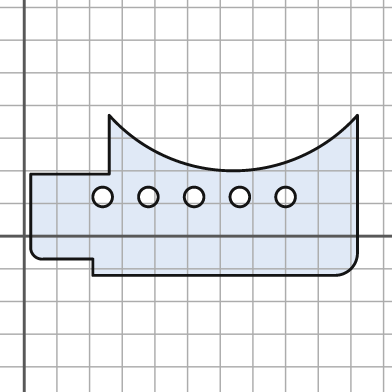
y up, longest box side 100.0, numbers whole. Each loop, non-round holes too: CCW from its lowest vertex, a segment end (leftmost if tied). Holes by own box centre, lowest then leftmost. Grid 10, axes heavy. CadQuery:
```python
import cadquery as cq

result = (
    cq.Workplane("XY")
    .moveTo(21.0, -12.0)
    .lineTo(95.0, -12.0)
    .threePointArc((100.0, -10.0), (102.0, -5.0))
    .lineTo(102.0, 37.0)
    .threePointArc((64.0, 20.0), (26.0, 37.0))
    .lineTo(26.0, 19.0)
    .lineTo(2.0, 19.0)
    .lineTo(2.0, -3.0)
    .threePointArc((3.0, -6.0), (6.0, -7.0))
    .lineTo(21.0, -7.0)
    .close()
    .moveTo(24.0, 12.0)
    .circle(3.0)
    .moveTo(38.0, 12.0)
    .circle(3.0)
    .moveTo(52.0, 12.0)
    .circle(3.0)
    .moveTo(66.0, 12.0)
    .circle(3.0)
    .moveTo(80.0, 12.0)
    .circle(3.0)
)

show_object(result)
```